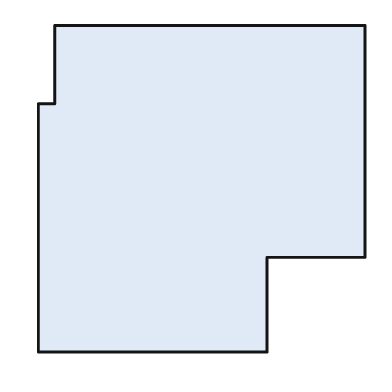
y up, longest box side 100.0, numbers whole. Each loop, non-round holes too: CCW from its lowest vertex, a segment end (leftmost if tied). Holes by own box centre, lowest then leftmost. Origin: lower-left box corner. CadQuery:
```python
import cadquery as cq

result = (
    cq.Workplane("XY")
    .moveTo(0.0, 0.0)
    .lineTo(70.0, 0.0)
    .lineTo(70.0, 29.0)
    .lineTo(100.0, 29.0)
    .lineTo(100.0, 100.0)
    .lineTo(5.0, 100.0)
    .lineTo(5.0, 76.0)
    .lineTo(0.0, 76.0)
    .close()
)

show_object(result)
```